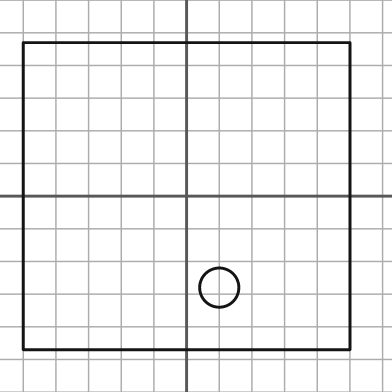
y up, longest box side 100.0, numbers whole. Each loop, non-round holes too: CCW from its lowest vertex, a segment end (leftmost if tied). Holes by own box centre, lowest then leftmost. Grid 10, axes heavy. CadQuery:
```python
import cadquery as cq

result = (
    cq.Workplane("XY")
    .moveTo(-50.0, -47.0)
    .lineTo(50.0, -47.0)
    .lineTo(50.0, 47.0)
    .lineTo(-50.0, 47.0)
    .close()
    .moveTo(10.0, -28.0)
    .circle(6.0)
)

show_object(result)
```